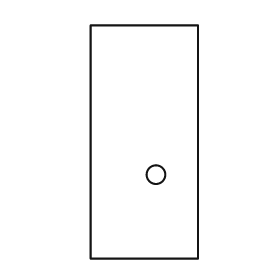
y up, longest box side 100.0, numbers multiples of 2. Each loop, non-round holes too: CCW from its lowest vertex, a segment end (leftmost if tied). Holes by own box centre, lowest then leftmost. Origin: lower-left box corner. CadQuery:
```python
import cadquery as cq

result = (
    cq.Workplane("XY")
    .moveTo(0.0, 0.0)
    .lineTo(46.0, 0.0)
    .lineTo(46.0, 100.0)
    .lineTo(0.0, 100.0)
    .close()
    .moveTo(28.0, 36.0)
    .circle(4.0)
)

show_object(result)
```